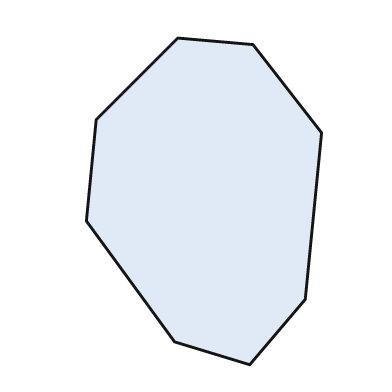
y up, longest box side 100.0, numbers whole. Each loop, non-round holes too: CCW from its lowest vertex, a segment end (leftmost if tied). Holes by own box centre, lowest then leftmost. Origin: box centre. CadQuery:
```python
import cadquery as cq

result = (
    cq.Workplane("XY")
    .moveTo(14.0, -50.0)
    .lineTo(31.0, -30.0)
    .lineTo(36.0, 21.0)
    .lineTo(15.0, 48.0)
    .lineTo(-8.0, 50.0)
    .lineTo(-33.0, 25.0)
    .lineTo(-36.0, -6.0)
    .lineTo(-9.0, -43.0)
    .close()
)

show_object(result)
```